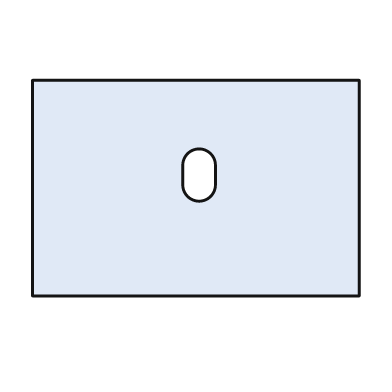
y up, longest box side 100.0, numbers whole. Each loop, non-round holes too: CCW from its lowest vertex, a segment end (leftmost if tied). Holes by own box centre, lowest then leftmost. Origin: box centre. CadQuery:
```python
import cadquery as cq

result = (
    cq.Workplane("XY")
    .moveTo(-50.0, -33.0)
    .lineTo(50.0, -33.0)
    .lineTo(50.0, 33.0)
    .lineTo(-50.0, 33.0)
    .close()
    .moveTo(-4.0, 1.0)
    .threePointArc((1.0, -4.0), (6.0, 1.0))
    .lineTo(6.0, 7.0)
    .threePointArc((1.0, 12.0), (-4.0, 7.0))
    .close()
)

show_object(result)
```